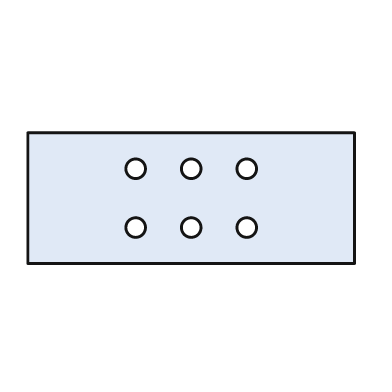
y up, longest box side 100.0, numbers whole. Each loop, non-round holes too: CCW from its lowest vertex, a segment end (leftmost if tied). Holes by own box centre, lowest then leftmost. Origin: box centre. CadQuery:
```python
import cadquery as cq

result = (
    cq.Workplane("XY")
    .moveTo(-50.0, -20.0)
    .lineTo(50.0, -20.0)
    .lineTo(50.0, 20.0)
    .lineTo(-50.0, 20.0)
    .close()
    .moveTo(-17.0, -9.0)
    .circle(3.0)
    .moveTo(0.0, -9.0)
    .circle(3.0)
    .moveTo(17.0, -9.0)
    .circle(3.0)
    .moveTo(-17.0, 9.0)
    .circle(3.0)
    .moveTo(0.0, 9.0)
    .circle(3.0)
    .moveTo(17.0, 9.0)
    .circle(3.0)
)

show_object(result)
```